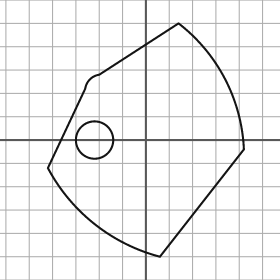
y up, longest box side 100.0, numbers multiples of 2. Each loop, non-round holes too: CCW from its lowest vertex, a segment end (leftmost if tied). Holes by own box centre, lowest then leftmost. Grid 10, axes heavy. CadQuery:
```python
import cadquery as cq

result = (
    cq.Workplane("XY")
    .moveTo(6.0, -50.0)
    .lineTo(42.0, -4.0)
    .threePointArc((34.0, 26.0), (14.0, 50.0))
    .lineTo(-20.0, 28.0)
    .threePointArc((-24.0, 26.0), (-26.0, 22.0))
    .lineTo(-42.0, -12.0)
    .threePointArc((-22.0, -36.0), (6.0, -50.0))
    .close()
    .moveTo(-22.0, 0.0)
    .circle(8.0)
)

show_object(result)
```